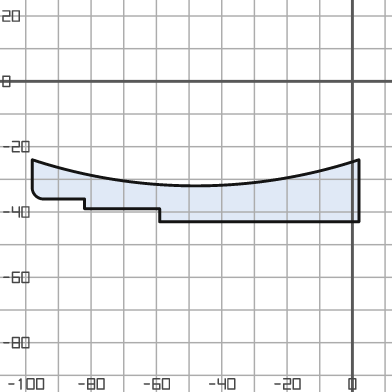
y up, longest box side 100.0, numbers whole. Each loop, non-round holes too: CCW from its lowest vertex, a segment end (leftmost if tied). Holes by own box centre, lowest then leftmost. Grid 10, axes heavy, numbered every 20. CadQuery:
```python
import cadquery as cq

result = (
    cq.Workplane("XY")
    .moveTo(-59.0, -43.0)
    .lineTo(2.0, -43.0)
    .lineTo(2.0, -24.0)
    .threePointArc((-48.0, -32.0), (-98.0, -24.0))
    .lineTo(-98.0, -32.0)
    .threePointArc((-97.0, -35.0), (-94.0, -36.0))
    .lineTo(-82.0, -36.0)
    .lineTo(-82.0, -39.0)
    .lineTo(-59.0, -39.0)
    .close()
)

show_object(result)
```